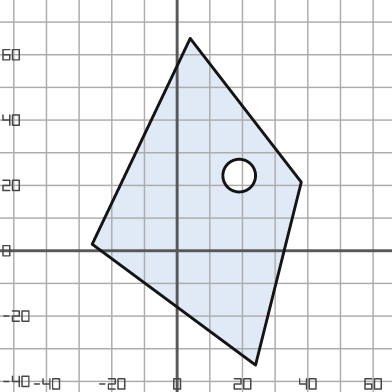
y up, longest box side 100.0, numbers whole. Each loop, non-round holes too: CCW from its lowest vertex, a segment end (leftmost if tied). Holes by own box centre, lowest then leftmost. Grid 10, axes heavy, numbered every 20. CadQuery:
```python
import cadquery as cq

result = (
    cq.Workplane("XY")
    .moveTo(24.0, -35.0)
    .lineTo(38.0, 21.0)
    .lineTo(4.0, 65.0)
    .lineTo(-26.0, 2.0)
    .close()
    .moveTo(19.0, 23.0)
    .circle(5.0)
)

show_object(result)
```